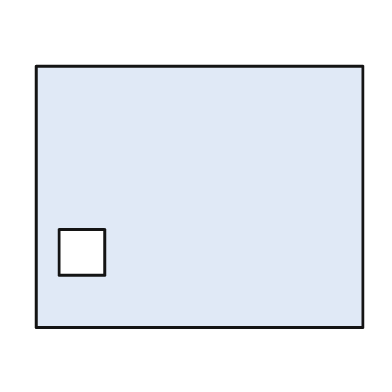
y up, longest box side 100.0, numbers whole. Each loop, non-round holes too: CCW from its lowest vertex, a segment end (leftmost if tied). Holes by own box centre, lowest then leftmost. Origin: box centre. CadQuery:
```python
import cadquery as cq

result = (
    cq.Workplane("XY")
    .moveTo(-50.0, -40.0)
    .lineTo(50.0, -40.0)
    .lineTo(50.0, 40.0)
    .lineTo(-50.0, 40.0)
    .close()
    .moveTo(-43.0, -24.0)
    .lineTo(-29.0, -24.0)
    .lineTo(-29.0, -10.0)
    .lineTo(-43.0, -10.0)
    .close()
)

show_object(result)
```